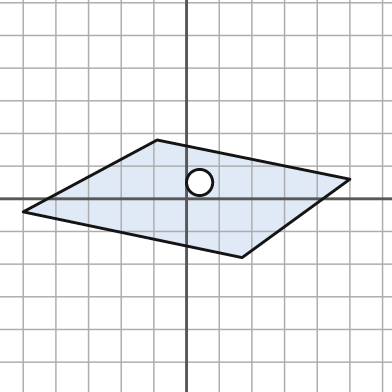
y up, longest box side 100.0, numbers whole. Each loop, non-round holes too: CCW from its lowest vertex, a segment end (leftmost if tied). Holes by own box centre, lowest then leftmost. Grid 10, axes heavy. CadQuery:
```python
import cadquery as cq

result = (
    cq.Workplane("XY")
    .moveTo(17.0, -18.0)
    .lineTo(50.0, 6.0)
    .lineTo(-9.0, 18.0)
    .lineTo(-50.0, -4.0)
    .close()
    .moveTo(4.0, 5.0)
    .circle(4.0)
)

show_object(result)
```